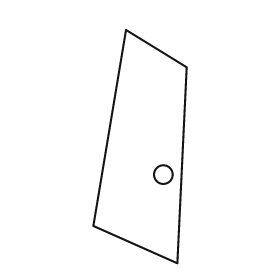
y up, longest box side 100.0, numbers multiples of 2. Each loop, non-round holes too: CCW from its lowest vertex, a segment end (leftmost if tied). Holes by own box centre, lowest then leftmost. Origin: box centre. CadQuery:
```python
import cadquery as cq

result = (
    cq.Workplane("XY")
    .moveTo(16.0, -50.0)
    .lineTo(20.0, 34.0)
    .lineTo(-6.0, 50.0)
    .lineTo(-20.0, -34.0)
    .close()
    .moveTo(10.0, -12.0)
    .circle(4.0)
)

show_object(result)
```